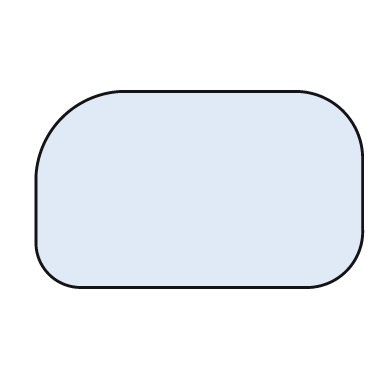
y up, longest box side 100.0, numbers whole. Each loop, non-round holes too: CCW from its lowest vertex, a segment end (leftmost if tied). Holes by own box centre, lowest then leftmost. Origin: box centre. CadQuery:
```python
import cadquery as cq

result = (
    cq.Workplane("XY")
    .moveTo(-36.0, -30.0)
    .lineTo(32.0, -30.0)
    .threePointArc((45.0, -25.0), (50.0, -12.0))
    .lineTo(50.0, 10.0)
    .threePointArc((44.0, 24.0), (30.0, 30.0))
    .lineTo(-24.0, 30.0)
    .threePointArc((-42.0, 22.0), (-50.0, 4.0))
    .lineTo(-50.0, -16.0)
    .threePointArc((-46.0, -26.0), (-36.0, -30.0))
    .close()
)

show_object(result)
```